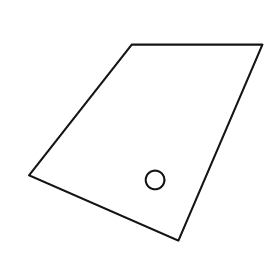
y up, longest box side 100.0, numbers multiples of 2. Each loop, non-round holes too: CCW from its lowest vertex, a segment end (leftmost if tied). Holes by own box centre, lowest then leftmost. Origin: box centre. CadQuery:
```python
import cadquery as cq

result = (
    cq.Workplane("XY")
    .moveTo(14.0, -42.0)
    .lineTo(50.0, 42.0)
    .lineTo(-6.0, 42.0)
    .lineTo(-50.0, -14.0)
    .close()
    .moveTo(4.0, -16.0)
    .circle(4.0)
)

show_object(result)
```